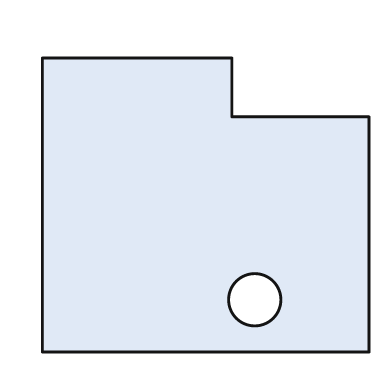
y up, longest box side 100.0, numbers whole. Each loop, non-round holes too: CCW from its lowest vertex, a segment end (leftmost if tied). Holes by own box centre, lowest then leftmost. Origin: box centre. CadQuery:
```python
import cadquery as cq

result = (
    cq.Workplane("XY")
    .moveTo(-50.0, -45.0)
    .lineTo(50.0, -45.0)
    .lineTo(50.0, 27.0)
    .lineTo(8.0, 27.0)
    .lineTo(8.0, 45.0)
    .lineTo(-50.0, 45.0)
    .close()
    .moveTo(15.0, -29.0)
    .circle(8.0)
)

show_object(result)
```